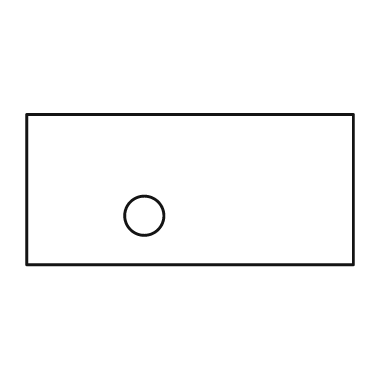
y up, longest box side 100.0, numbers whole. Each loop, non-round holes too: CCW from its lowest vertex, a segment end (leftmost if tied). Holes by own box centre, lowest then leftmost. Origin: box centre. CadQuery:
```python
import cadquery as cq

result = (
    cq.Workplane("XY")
    .moveTo(-50.0, -23.0)
    .lineTo(50.0, -23.0)
    .lineTo(50.0, 23.0)
    .lineTo(-50.0, 23.0)
    .close()
    .moveTo(-14.0, -8.0)
    .circle(6.0)
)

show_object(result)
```